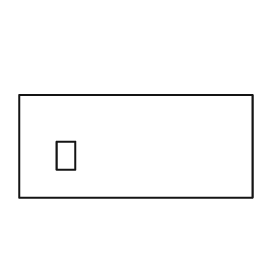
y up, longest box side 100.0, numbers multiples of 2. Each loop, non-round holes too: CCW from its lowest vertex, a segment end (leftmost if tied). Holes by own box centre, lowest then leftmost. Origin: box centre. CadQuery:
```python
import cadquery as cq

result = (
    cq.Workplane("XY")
    .moveTo(-50.0, -22.0)
    .lineTo(50.0, -22.0)
    .lineTo(50.0, 22.0)
    .lineTo(-50.0, 22.0)
    .close()
    .moveTo(-34.0, -10.0)
    .lineTo(-26.0, -10.0)
    .lineTo(-26.0, 2.0)
    .lineTo(-34.0, 2.0)
    .close()
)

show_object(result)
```